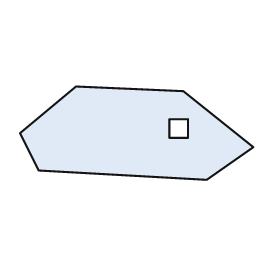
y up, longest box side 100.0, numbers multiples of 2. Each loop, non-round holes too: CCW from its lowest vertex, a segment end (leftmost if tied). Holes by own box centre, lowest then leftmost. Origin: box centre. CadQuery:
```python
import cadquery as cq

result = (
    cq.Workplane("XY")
    .moveTo(30.0, -20.0)
    .lineTo(50.0, -6.0)
    .lineTo(20.0, 18.0)
    .lineTo(-26.0, 20.0)
    .lineTo(-50.0, 0.0)
    .lineTo(-42.0, -16.0)
    .close()
    .moveTo(14.0, -2.0)
    .lineTo(22.0, -2.0)
    .lineTo(22.0, 6.0)
    .lineTo(14.0, 6.0)
    .close()
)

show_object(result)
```